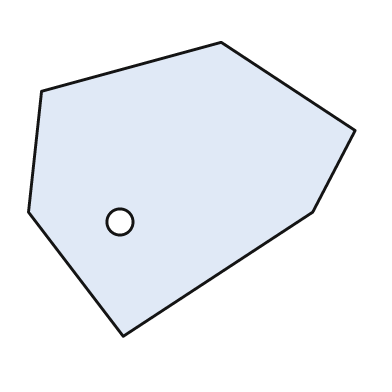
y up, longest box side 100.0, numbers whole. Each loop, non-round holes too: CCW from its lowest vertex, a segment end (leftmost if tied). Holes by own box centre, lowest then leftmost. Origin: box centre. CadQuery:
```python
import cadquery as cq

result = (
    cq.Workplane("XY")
    .moveTo(-21.0, -45.0)
    .lineTo(37.0, -7.0)
    .lineTo(50.0, 18.0)
    .lineTo(9.0, 45.0)
    .lineTo(-46.0, 30.0)
    .lineTo(-50.0, -7.0)
    .close()
    .moveTo(-22.0, -10.0)
    .circle(4.0)
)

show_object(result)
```